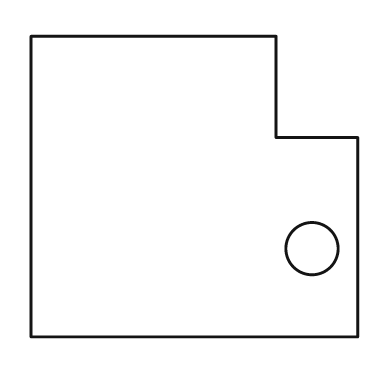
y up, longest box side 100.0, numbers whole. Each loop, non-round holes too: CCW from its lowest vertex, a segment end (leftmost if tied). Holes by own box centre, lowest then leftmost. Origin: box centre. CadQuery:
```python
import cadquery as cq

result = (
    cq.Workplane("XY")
    .moveTo(-50.0, -46.0)
    .lineTo(50.0, -46.0)
    .lineTo(50.0, 15.0)
    .lineTo(25.0, 15.0)
    .lineTo(25.0, 46.0)
    .lineTo(-50.0, 46.0)
    .close()
    .moveTo(36.0, -19.0)
    .circle(8.0)
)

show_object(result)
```